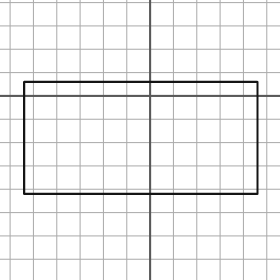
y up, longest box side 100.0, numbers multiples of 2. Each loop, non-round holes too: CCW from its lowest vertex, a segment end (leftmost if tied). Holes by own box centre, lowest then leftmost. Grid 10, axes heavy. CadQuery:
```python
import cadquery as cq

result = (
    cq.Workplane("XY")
    .moveTo(-54.0, -42.0)
    .lineTo(46.0, -42.0)
    .lineTo(46.0, 6.0)
    .lineTo(-54.0, 6.0)
    .close()
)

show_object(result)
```